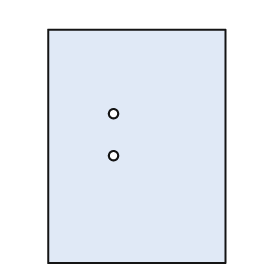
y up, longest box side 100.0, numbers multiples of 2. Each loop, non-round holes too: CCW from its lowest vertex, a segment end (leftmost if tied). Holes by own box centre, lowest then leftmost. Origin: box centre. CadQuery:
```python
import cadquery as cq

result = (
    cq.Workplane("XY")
    .moveTo(-38.0, -50.0)
    .lineTo(38.0, -50.0)
    .lineTo(38.0, 50.0)
    .lineTo(-38.0, 50.0)
    .close()
    .moveTo(-10.0, -4.0)
    .circle(2.0)
    .moveTo(-10.0, 14.0)
    .circle(2.0)
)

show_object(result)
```